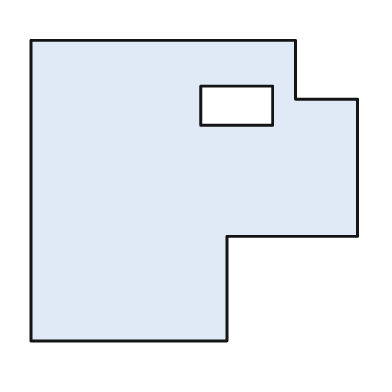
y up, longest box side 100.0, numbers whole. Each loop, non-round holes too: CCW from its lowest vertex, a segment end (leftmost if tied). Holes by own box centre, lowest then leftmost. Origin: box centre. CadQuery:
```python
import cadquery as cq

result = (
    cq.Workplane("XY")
    .moveTo(-50.0, -46.0)
    .lineTo(10.0, -46.0)
    .lineTo(10.0, -14.0)
    .lineTo(50.0, -14.0)
    .lineTo(50.0, 28.0)
    .lineTo(31.0, 28.0)
    .lineTo(31.0, 46.0)
    .lineTo(-50.0, 46.0)
    .close()
    .moveTo(2.0, 20.0)
    .lineTo(24.0, 20.0)
    .lineTo(24.0, 32.0)
    .lineTo(2.0, 32.0)
    .close()
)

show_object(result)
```